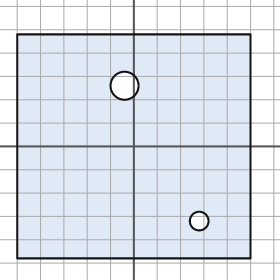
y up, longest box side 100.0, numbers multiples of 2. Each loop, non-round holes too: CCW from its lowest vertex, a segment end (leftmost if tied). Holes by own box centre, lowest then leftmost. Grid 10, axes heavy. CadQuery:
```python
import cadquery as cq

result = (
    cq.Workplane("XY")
    .moveTo(-50.0, -48.0)
    .lineTo(50.0, -48.0)
    .lineTo(50.0, 48.0)
    .lineTo(-50.0, 48.0)
    .close()
    .moveTo(28.0, -32.0)
    .circle(4.0)
    .moveTo(-4.0, 26.0)
    .circle(6.0)
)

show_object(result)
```